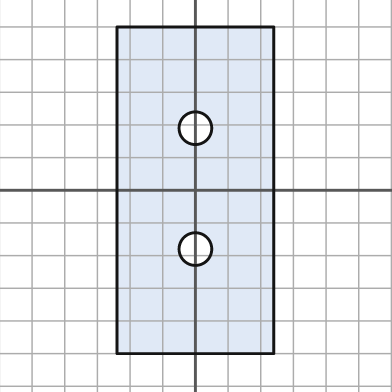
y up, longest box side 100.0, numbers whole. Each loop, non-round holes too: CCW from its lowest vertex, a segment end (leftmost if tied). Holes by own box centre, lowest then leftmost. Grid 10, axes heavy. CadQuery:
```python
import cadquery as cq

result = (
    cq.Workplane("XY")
    .moveTo(-24.0, -50.0)
    .lineTo(24.0, -50.0)
    .lineTo(24.0, 50.0)
    .lineTo(-24.0, 50.0)
    .close()
    .moveTo(0.0, -18.0)
    .circle(5.0)
    .moveTo(0.0, 19.0)
    .circle(5.0)
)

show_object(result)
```